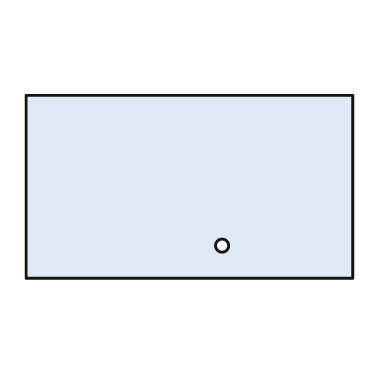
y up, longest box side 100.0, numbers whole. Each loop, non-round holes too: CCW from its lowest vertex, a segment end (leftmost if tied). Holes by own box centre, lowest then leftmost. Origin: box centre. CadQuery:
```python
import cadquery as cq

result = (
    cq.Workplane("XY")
    .moveTo(-50.0, -28.0)
    .lineTo(50.0, -28.0)
    .lineTo(50.0, 28.0)
    .lineTo(-50.0, 28.0)
    .close()
    .moveTo(10.0, -18.0)
    .circle(2.0)
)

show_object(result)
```